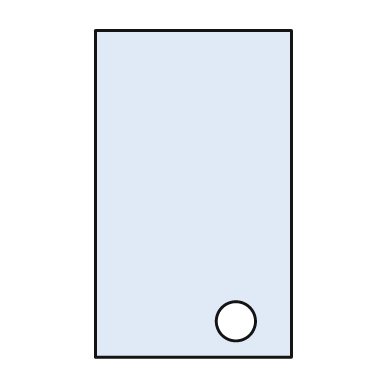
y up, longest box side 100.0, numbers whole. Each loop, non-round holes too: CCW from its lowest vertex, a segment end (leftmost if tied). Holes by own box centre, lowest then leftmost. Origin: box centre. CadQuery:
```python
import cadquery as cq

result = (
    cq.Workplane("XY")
    .moveTo(-30.0, -50.0)
    .lineTo(30.0, -50.0)
    .lineTo(30.0, 50.0)
    .lineTo(-30.0, 50.0)
    .close()
    .moveTo(13.0, -39.0)
    .circle(6.0)
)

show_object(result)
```